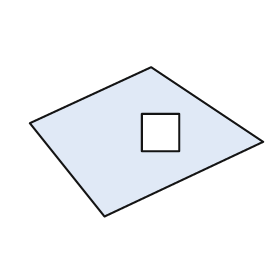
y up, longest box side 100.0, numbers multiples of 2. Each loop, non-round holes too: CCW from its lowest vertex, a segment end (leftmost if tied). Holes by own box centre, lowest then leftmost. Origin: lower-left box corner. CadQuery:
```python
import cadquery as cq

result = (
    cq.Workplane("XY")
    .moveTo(32.0, 0.0)
    .lineTo(100.0, 32.0)
    .lineTo(52.0, 64.0)
    .lineTo(0.0, 40.0)
    .close()
    .moveTo(48.0, 28.0)
    .lineTo(64.0, 28.0)
    .lineTo(64.0, 44.0)
    .lineTo(48.0, 44.0)
    .close()
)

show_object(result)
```